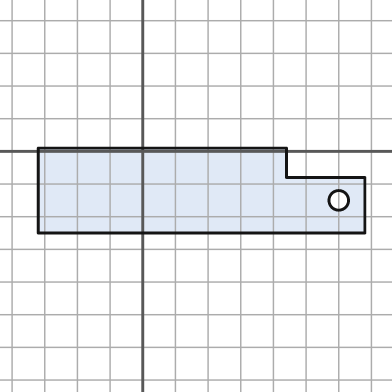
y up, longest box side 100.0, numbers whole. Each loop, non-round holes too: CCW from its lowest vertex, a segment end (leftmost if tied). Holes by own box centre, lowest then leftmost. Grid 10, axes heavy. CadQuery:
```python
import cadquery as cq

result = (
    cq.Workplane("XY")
    .moveTo(-32.0, -25.0)
    .lineTo(68.0, -25.0)
    .lineTo(68.0, -8.0)
    .lineTo(44.0, -8.0)
    .lineTo(44.0, 1.0)
    .lineTo(-32.0, 1.0)
    .close()
    .moveTo(60.0, -15.0)
    .circle(3.0)
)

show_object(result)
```